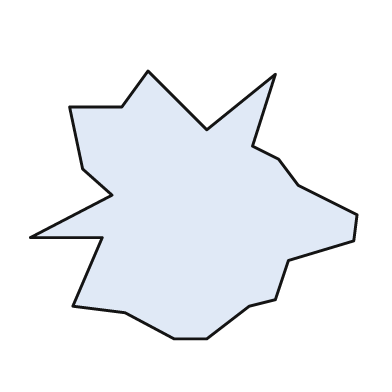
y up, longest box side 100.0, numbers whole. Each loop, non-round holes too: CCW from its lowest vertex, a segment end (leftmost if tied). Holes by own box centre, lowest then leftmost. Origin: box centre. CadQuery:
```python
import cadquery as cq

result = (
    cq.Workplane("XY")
    .moveTo(-6.0, -41.0)
    .lineTo(4.0, -41.0)
    .lineTo(17.0, -31.0)
    .lineTo(25.0, -29.0)
    .lineTo(29.0, -17.0)
    .lineTo(49.0, -11.0)
    .lineTo(50.0, -3.0)
    .lineTo(32.0, 6.0)
    .lineTo(26.0, 14.0)
    .lineTo(18.0, 18.0)
    .lineTo(25.0, 40.0)
    .lineTo(4.0, 23.0)
    .lineTo(-14.0, 41.0)
    .lineTo(-22.0, 30.0)
    .lineTo(-38.0, 30.0)
    .lineTo(-34.0, 11.0)
    .lineTo(-25.0, 3.0)
    .lineTo(-50.0, -10.0)
    .lineTo(-28.0, -10.0)
    .lineTo(-37.0, -31.0)
    .lineTo(-21.0, -33.0)
    .close()
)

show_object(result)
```